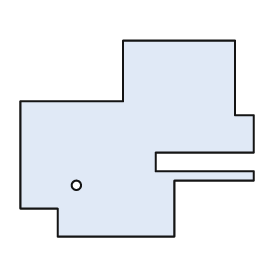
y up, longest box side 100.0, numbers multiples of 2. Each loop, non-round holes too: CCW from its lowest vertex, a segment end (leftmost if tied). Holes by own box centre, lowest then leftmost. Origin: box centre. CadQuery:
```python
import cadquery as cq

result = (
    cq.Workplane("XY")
    .moveTo(-34.0, -42.0)
    .lineTo(16.0, -42.0)
    .lineTo(16.0, -18.0)
    .lineTo(50.0, -18.0)
    .lineTo(50.0, -14.0)
    .lineTo(8.0, -14.0)
    .lineTo(8.0, -6.0)
    .lineTo(50.0, -6.0)
    .lineTo(50.0, 10.0)
    .lineTo(42.0, 10.0)
    .lineTo(42.0, 42.0)
    .lineTo(-6.0, 42.0)
    .lineTo(-6.0, 16.0)
    .lineTo(-50.0, 16.0)
    .lineTo(-50.0, -30.0)
    .lineTo(-34.0, -30.0)
    .close()
    .moveTo(-26.0, -20.0)
    .circle(2.0)
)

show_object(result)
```